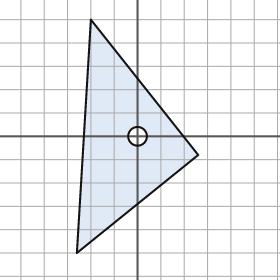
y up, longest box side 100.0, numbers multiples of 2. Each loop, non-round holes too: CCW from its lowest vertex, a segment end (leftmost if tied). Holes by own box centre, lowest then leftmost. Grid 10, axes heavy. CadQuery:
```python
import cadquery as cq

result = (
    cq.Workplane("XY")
    .moveTo(-26.0, -50.0)
    .lineTo(26.0, -8.0)
    .lineTo(-20.0, 50.0)
    .close()
    .moveTo(0.0, 0.0)
    .circle(4.0)
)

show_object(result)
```